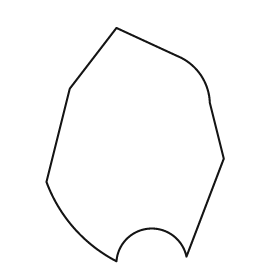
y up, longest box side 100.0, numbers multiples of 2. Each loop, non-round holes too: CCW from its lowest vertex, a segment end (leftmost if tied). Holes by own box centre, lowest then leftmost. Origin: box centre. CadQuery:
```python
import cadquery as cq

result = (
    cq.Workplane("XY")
    .moveTo(-8.0, -50.0)
    .threePointArc((6.0, -36.0), (22.0, -48.0))
    .lineTo(38.0, -6.0)
    .lineTo(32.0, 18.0)
    .threePointArc((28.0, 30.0), (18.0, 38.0))
    .lineTo(-8.0, 50.0)
    .lineTo(-28.0, 24.0)
    .lineTo(-38.0, -16.0)
    .threePointArc((-26.0, -36.0), (-8.0, -50.0))
    .close()
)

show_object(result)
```